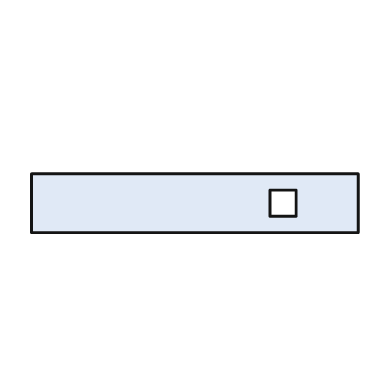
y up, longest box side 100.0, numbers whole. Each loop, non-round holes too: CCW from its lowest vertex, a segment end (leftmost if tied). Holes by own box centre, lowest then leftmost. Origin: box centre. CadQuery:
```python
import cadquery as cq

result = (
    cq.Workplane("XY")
    .moveTo(-50.0, -9.0)
    .lineTo(50.0, -9.0)
    .lineTo(50.0, 9.0)
    .lineTo(-50.0, 9.0)
    .close()
    .moveTo(23.0, -4.0)
    .lineTo(31.0, -4.0)
    .lineTo(31.0, 4.0)
    .lineTo(23.0, 4.0)
    .close()
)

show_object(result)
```